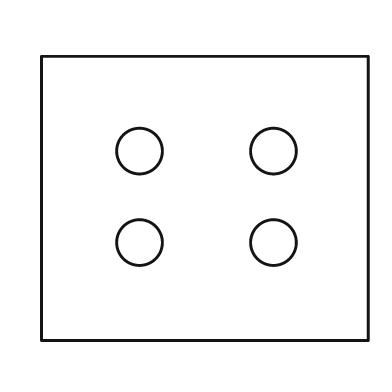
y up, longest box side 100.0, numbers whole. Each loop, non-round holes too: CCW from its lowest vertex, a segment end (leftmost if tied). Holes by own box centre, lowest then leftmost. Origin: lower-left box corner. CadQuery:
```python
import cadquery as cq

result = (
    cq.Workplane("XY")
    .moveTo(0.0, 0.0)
    .lineTo(100.0, 0.0)
    .lineTo(100.0, 87.0)
    .lineTo(0.0, 87.0)
    .close()
    .moveTo(30.0, 30.0)
    .circle(7.0)
    .moveTo(71.0, 30.0)
    .circle(7.0)
    .moveTo(30.0, 58.0)
    .circle(7.0)
    .moveTo(71.0, 58.0)
    .circle(7.0)
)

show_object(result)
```